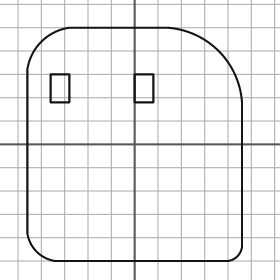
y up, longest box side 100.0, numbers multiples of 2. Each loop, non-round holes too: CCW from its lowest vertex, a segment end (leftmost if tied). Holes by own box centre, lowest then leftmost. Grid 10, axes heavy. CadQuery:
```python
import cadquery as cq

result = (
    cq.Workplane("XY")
    .moveTo(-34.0, -50.0)
    .lineTo(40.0, -50.0)
    .threePointArc((44.0, -48.0), (46.0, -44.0))
    .lineTo(46.0, 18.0)
    .threePointArc((36.0, 40.0), (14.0, 50.0))
    .lineTo(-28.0, 50.0)
    .threePointArc((-40.0, 44.0), (-46.0, 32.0))
    .lineTo(-46.0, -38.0)
    .threePointArc((-42.0, -46.0), (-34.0, -50.0))
    .close()
    .moveTo(-36.0, 18.0)
    .lineTo(-28.0, 18.0)
    .lineTo(-28.0, 30.0)
    .lineTo(-36.0, 30.0)
    .close()
    .moveTo(0.0, 18.0)
    .lineTo(8.0, 18.0)
    .lineTo(8.0, 30.0)
    .lineTo(0.0, 30.0)
    .close()
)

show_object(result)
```